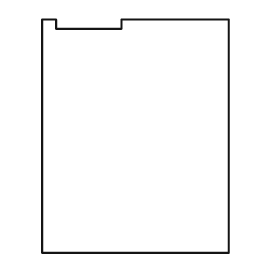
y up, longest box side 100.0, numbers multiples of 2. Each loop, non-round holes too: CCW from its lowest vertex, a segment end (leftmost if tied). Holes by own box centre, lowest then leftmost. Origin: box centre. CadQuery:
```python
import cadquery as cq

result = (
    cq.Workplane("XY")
    .moveTo(-40.0, -50.0)
    .lineTo(40.0, -50.0)
    .lineTo(40.0, 50.0)
    .lineTo(-6.0, 50.0)
    .lineTo(-6.0, 46.0)
    .lineTo(-34.0, 46.0)
    .lineTo(-34.0, 50.0)
    .lineTo(-40.0, 50.0)
    .close()
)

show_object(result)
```